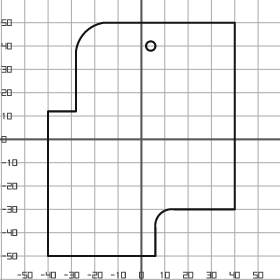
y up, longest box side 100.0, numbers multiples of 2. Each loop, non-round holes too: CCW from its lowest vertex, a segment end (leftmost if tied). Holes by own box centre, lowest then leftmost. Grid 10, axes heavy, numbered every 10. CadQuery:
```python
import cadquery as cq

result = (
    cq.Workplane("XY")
    .moveTo(-40.0, -50.0)
    .lineTo(6.0, -50.0)
    .lineTo(6.0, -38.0)
    .threePointArc((8.0, -32.0), (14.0, -30.0))
    .lineTo(40.0, -30.0)
    .lineTo(40.0, 50.0)
    .lineTo(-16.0, 50.0)
    .threePointArc((-24.0, 46.0), (-28.0, 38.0))
    .lineTo(-28.0, 12.0)
    .lineTo(-40.0, 12.0)
    .close()
    .moveTo(4.0, 40.0)
    .circle(2.0)
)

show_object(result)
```